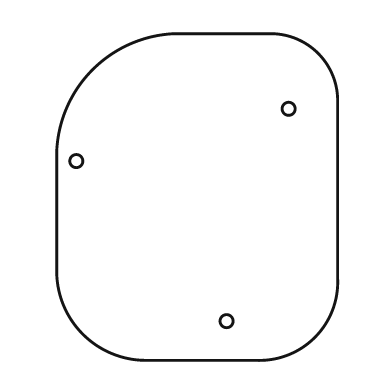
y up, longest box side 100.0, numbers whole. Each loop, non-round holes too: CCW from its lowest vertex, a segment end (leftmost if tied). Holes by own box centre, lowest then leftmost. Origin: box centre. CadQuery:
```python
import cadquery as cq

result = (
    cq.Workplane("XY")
    .moveTo(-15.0, -50.0)
    .lineTo(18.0, -50.0)
    .threePointArc((36.0, -43.0), (43.0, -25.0))
    .lineTo(43.0, 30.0)
    .threePointArc((37.0, 44.0), (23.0, 50.0))
    .lineTo(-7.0, 50.0)
    .threePointArc((-32.0, 39.0), (-43.0, 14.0))
    .lineTo(-43.0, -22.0)
    .threePointArc((-35.0, -42.0), (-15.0, -50.0))
    .close()
    .moveTo(9.0, -38.0)
    .circle(2.0)
    .moveTo(-37.0, 11.0)
    .circle(2.0)
    .moveTo(28.0, 27.0)
    .circle(2.0)
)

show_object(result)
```